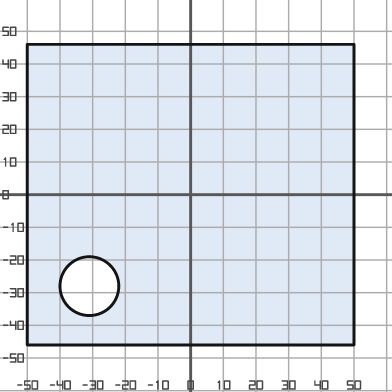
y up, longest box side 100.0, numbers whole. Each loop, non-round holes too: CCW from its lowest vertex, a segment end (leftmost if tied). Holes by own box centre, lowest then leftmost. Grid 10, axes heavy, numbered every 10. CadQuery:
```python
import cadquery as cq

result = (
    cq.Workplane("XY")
    .moveTo(-50.0, -46.0)
    .lineTo(50.0, -46.0)
    .lineTo(50.0, 46.0)
    .lineTo(-50.0, 46.0)
    .close()
    .moveTo(-31.0, -28.0)
    .circle(9.0)
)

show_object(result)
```